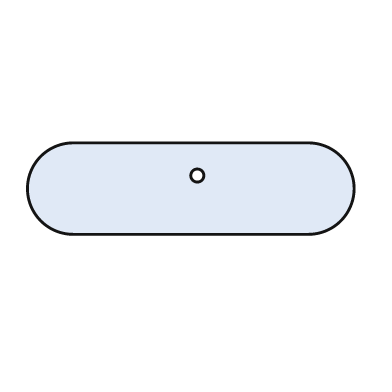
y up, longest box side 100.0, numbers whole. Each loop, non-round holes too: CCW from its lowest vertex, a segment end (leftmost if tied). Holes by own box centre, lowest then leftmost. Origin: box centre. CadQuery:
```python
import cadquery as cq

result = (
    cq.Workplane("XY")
    .moveTo(-36.0, -14.0)
    .lineTo(36.0, -14.0)
    .threePointArc((50.0, 0.0), (36.0, 14.0))
    .lineTo(-36.0, 14.0)
    .threePointArc((-50.0, 0.0), (-36.0, -14.0))
    .close()
    .moveTo(2.0, 4.0)
    .circle(2.0)
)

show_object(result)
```